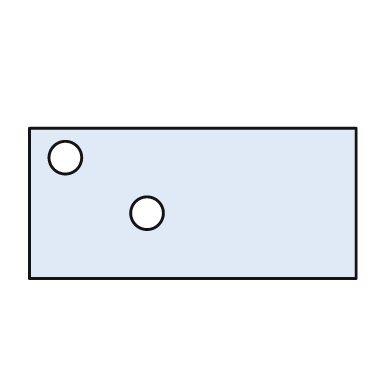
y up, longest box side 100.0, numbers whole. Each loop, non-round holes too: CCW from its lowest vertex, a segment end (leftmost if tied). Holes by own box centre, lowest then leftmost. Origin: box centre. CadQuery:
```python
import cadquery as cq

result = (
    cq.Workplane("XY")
    .moveTo(-50.0, -23.0)
    .lineTo(50.0, -23.0)
    .lineTo(50.0, 23.0)
    .lineTo(-50.0, 23.0)
    .close()
    .moveTo(-14.0, -3.0)
    .circle(5.0)
    .moveTo(-39.0, 14.0)
    .circle(5.0)
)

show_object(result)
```